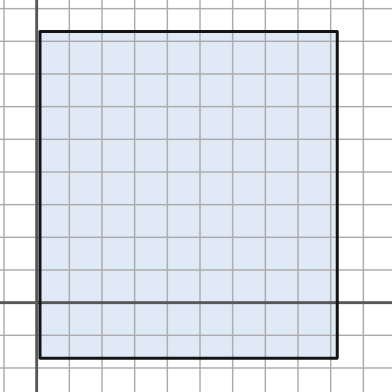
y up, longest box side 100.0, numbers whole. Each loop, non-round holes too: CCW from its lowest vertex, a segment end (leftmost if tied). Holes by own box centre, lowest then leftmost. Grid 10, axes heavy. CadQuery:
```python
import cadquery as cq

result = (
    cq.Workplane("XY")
    .moveTo(1.0, -17.0)
    .lineTo(92.0, -17.0)
    .lineTo(92.0, 83.0)
    .lineTo(1.0, 83.0)
    .close()
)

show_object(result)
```